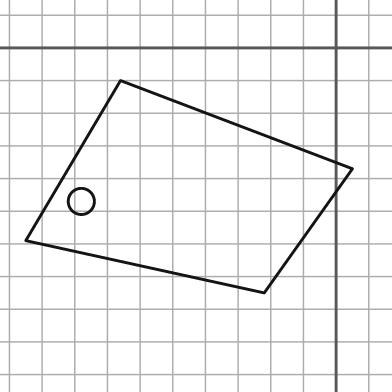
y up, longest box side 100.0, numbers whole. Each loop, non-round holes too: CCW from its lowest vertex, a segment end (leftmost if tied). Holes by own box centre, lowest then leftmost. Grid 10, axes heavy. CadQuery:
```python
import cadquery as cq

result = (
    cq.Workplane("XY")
    .moveTo(-22.0, -75.0)
    .lineTo(5.0, -37.0)
    .lineTo(-66.0, -10.0)
    .lineTo(-95.0, -59.0)
    .close()
    .moveTo(-78.0, -47.0)
    .circle(4.0)
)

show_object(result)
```